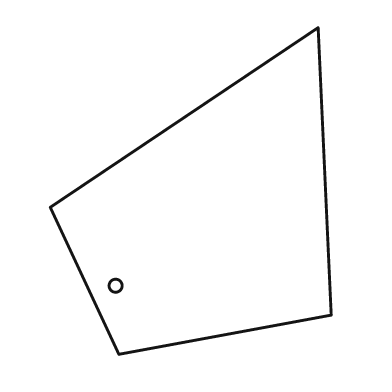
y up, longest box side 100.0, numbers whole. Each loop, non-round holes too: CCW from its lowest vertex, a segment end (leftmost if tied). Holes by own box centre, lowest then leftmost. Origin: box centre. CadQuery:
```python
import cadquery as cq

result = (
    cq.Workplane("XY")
    .moveTo(-22.0, -50.0)
    .lineTo(43.0, -38.0)
    .lineTo(39.0, 50.0)
    .lineTo(-43.0, -5.0)
    .close()
    .moveTo(-23.0, -29.0)
    .circle(2.0)
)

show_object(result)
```